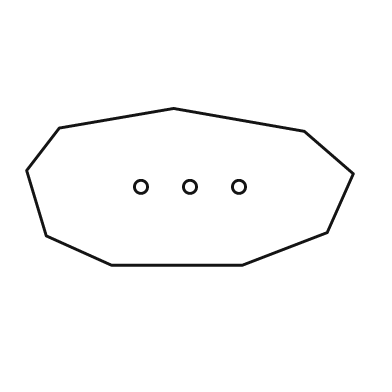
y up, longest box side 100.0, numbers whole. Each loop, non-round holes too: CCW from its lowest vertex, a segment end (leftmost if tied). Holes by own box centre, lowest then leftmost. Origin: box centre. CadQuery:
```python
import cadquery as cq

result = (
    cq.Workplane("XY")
    .moveTo(-24.0, -24.0)
    .lineTo(16.0, -24.0)
    .lineTo(42.0, -14.0)
    .lineTo(50.0, 4.0)
    .lineTo(35.0, 17.0)
    .lineTo(-5.0, 24.0)
    .lineTo(-40.0, 18.0)
    .lineTo(-50.0, 5.0)
    .lineTo(-44.0, -15.0)
    .close()
    .moveTo(-15.0, 0.0)
    .circle(2.0)
    .moveTo(0.0, 0.0)
    .circle(2.0)
    .moveTo(15.0, 0.0)
    .circle(2.0)
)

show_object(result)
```